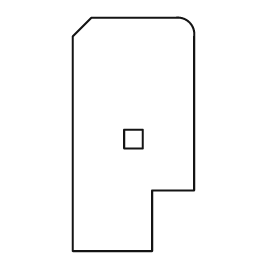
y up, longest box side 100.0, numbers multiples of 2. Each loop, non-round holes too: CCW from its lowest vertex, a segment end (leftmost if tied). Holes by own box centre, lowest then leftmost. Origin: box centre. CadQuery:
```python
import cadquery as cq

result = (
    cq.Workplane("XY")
    .moveTo(-26.0, -50.0)
    .lineTo(8.0, -50.0)
    .lineTo(8.0, -24.0)
    .lineTo(26.0, -24.0)
    .lineTo(26.0, 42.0)
    .threePointArc((24.0, 48.0), (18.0, 50.0))
    .lineTo(-18.0, 50.0)
    .lineTo(-26.0, 42.0)
    .close()
    .moveTo(-4.0, -6.0)
    .lineTo(4.0, -6.0)
    .lineTo(4.0, 2.0)
    .lineTo(-4.0, 2.0)
    .close()
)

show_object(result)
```